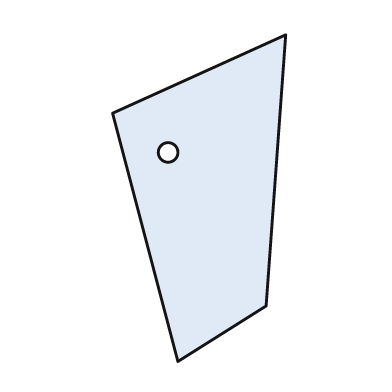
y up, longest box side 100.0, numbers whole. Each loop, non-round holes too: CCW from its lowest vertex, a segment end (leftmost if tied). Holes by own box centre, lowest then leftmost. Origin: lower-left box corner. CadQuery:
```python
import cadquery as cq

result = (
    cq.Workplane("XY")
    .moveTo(20.0, 0.0)
    .lineTo(47.0, 17.0)
    .lineTo(53.0, 100.0)
    .lineTo(0.0, 76.0)
    .close()
    .moveTo(17.0, 64.0)
    .circle(3.0)
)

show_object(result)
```